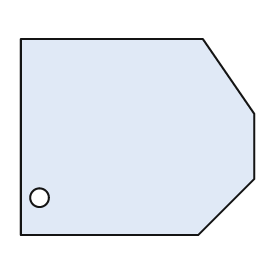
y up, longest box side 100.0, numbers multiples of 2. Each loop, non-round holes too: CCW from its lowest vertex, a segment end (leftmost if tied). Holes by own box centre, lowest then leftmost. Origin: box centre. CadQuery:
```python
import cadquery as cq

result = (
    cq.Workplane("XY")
    .moveTo(-50.0, -42.0)
    .lineTo(26.0, -42.0)
    .lineTo(50.0, -18.0)
    .lineTo(50.0, 10.0)
    .lineTo(28.0, 42.0)
    .lineTo(-50.0, 42.0)
    .close()
    .moveTo(-42.0, -26.0)
    .circle(4.0)
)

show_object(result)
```